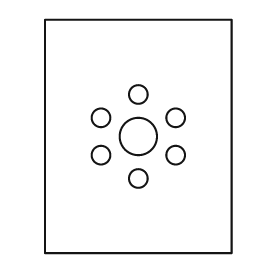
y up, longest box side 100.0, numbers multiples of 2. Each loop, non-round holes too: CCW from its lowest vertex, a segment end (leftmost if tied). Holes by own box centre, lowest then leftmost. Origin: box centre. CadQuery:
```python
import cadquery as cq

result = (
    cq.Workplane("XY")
    .moveTo(-40.0, -50.0)
    .lineTo(40.0, -50.0)
    .lineTo(40.0, 50.0)
    .lineTo(-40.0, 50.0)
    .close()
    .moveTo(0.0, -18.0)
    .circle(4.0)
    .moveTo(-16.0, -8.0)
    .circle(4.0)
    .moveTo(16.0, -8.0)
    .circle(4.0)
    .moveTo(0.0, 0.0)
    .circle(8.0)
    .moveTo(-16.0, 8.0)
    .circle(4.0)
    .moveTo(16.0, 8.0)
    .circle(4.0)
    .moveTo(0.0, 18.0)
    .circle(4.0)
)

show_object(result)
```